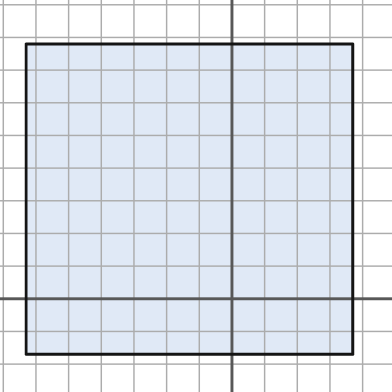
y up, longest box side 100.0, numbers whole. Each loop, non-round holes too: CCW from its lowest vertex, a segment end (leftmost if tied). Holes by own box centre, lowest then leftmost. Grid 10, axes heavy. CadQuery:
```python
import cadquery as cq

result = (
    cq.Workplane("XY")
    .moveTo(-63.0, -17.0)
    .lineTo(37.0, -17.0)
    .lineTo(37.0, 78.0)
    .lineTo(-63.0, 78.0)
    .close()
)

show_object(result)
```